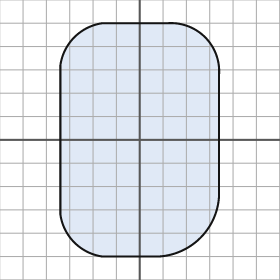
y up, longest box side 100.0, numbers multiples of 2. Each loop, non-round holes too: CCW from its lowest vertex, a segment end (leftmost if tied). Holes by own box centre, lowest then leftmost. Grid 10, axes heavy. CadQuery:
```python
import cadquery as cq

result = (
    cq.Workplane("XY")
    .moveTo(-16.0, -50.0)
    .lineTo(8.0, -50.0)
    .threePointArc((26.0, -42.0), (34.0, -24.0))
    .lineTo(34.0, 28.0)
    .threePointArc((28.0, 44.0), (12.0, 50.0))
    .lineTo(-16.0, 50.0)
    .threePointArc((-28.0, 44.0), (-34.0, 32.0))
    .lineTo(-34.0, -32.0)
    .threePointArc((-28.0, -44.0), (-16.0, -50.0))
    .close()
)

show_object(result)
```